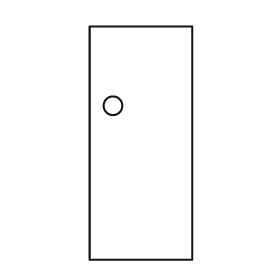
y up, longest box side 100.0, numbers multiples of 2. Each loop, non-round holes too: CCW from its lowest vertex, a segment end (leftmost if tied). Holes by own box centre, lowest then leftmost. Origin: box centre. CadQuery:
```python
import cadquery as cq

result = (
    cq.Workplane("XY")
    .moveTo(-22.0, -50.0)
    .lineTo(22.0, -50.0)
    .lineTo(22.0, 50.0)
    .lineTo(-22.0, 50.0)
    .close()
    .moveTo(-12.0, 16.0)
    .circle(4.0)
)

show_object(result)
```